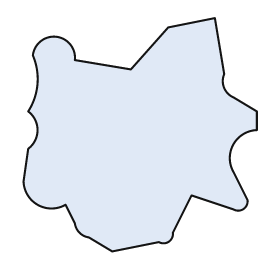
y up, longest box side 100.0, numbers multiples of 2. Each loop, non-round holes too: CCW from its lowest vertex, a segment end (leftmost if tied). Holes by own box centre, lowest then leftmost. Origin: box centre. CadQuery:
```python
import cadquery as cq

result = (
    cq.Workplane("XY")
    .moveTo(-12.0, -50.0)
    .lineTo(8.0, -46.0)
    .threePointArc((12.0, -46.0), (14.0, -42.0))
    .lineTo(22.0, -26.0)
    .lineTo(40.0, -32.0)
    .threePointArc((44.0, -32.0), (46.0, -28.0))
    .lineTo(40.0, -16.0)
    .threePointArc((40.0, -4.0), (50.0, 2.0))
    .lineTo(50.0, 10.0)
    .lineTo(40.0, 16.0)
    .threePointArc((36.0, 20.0), (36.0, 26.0))
    .lineTo(32.0, 50.0)
    .lineTo(12.0, 46.0)
    .lineTo(-4.0, 28.0)
    .lineTo(-28.0, 32.0)
    .threePointArc((-36.0, 42.0), (-46.0, 34.0))
    .threePointArc((-44.0, 22.0), (-48.0, 10.0))
    .threePointArc((-44.0, 2.0), (-48.0, -6.0))
    .lineTo(-50.0, -20.0)
    .threePointArc((-44.0, -30.0), (-32.0, -30.0))
    .lineTo(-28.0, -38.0)
    .threePointArc((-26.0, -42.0), (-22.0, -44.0))
    .close()
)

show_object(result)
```